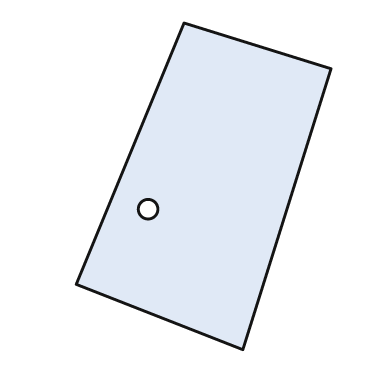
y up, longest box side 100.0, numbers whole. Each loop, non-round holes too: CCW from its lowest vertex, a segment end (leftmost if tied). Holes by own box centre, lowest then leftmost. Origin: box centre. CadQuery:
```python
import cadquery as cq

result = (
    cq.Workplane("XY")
    .moveTo(12.0, -50.0)
    .lineTo(39.0, 36.0)
    .lineTo(-6.0, 50.0)
    .lineTo(-39.0, -30.0)
    .close()
    .moveTo(-17.0, -7.0)
    .circle(3.0)
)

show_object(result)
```